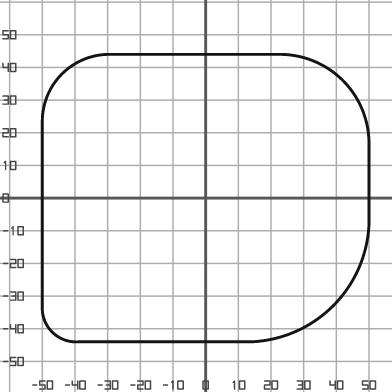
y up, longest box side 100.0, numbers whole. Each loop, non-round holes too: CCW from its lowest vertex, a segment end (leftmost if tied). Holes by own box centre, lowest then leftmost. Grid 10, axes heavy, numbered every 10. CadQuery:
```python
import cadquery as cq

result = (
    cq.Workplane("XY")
    .moveTo(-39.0, -44.0)
    .lineTo(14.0, -44.0)
    .threePointArc((39.0, -33.0), (50.0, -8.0))
    .lineTo(50.0, 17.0)
    .threePointArc((42.0, 36.0), (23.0, 44.0))
    .lineTo(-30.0, 44.0)
    .threePointArc((-44.0, 38.0), (-50.0, 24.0))
    .lineTo(-50.0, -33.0)
    .threePointArc((-47.0, -41.0), (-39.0, -44.0))
    .close()
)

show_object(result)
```